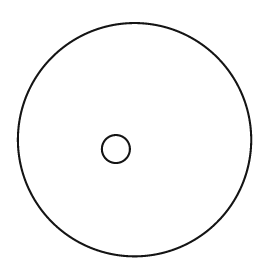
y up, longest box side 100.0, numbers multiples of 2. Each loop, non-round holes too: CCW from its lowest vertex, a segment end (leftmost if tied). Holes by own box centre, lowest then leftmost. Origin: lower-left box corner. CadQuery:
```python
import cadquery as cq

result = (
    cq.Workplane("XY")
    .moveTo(50.0, 50.0)
    .circle(50.0)
    .moveTo(42.0, 46.0)
    .circle(6.0)
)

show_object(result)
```